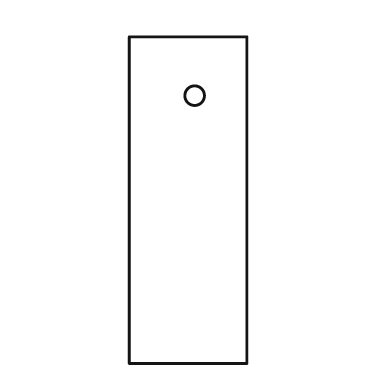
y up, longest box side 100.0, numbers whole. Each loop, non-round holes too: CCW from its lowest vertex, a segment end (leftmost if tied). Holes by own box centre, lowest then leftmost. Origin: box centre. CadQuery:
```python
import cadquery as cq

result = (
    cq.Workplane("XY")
    .moveTo(-18.0, -50.0)
    .lineTo(18.0, -50.0)
    .lineTo(18.0, 50.0)
    .lineTo(-18.0, 50.0)
    .close()
    .moveTo(2.0, 32.0)
    .circle(3.0)
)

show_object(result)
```